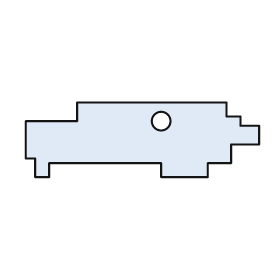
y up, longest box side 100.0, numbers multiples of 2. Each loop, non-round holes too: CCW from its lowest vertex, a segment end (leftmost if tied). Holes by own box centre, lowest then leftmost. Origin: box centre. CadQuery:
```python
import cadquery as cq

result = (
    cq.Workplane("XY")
    .moveTo(-46.0, -16.0)
    .lineTo(-40.0, -16.0)
    .lineTo(-40.0, -10.0)
    .lineTo(8.0, -10.0)
    .lineTo(8.0, -16.0)
    .lineTo(28.0, -16.0)
    .lineTo(28.0, -10.0)
    .lineTo(38.0, -10.0)
    .lineTo(38.0, -2.0)
    .lineTo(50.0, -2.0)
    .lineTo(50.0, 6.0)
    .lineTo(42.0, 6.0)
    .lineTo(42.0, 10.0)
    .lineTo(36.0, 10.0)
    .lineTo(36.0, 16.0)
    .lineTo(-28.0, 16.0)
    .lineTo(-28.0, 8.0)
    .lineTo(-50.0, 8.0)
    .lineTo(-50.0, -8.0)
    .lineTo(-46.0, -8.0)
    .close()
    .moveTo(8.0, 8.0)
    .circle(4.0)
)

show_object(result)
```